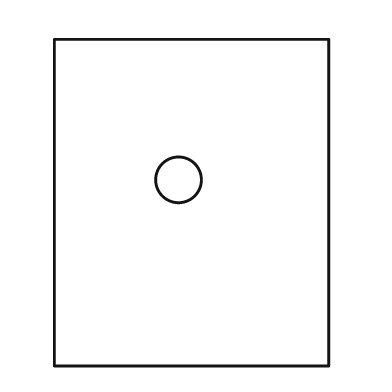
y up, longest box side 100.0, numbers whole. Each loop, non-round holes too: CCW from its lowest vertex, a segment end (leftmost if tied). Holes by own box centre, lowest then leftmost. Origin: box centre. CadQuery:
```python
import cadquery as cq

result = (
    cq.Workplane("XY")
    .moveTo(-42.0, -50.0)
    .lineTo(42.0, -50.0)
    .lineTo(42.0, 50.0)
    .lineTo(-42.0, 50.0)
    .close()
    .moveTo(-4.0, 7.0)
    .circle(7.0)
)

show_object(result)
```